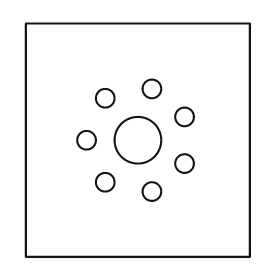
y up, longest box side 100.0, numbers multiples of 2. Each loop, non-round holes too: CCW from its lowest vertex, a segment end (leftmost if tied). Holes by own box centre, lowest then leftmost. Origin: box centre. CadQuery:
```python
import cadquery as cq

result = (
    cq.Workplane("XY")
    .moveTo(-48.0, -50.0)
    .lineTo(48.0, -50.0)
    .lineTo(48.0, 50.0)
    .lineTo(-48.0, 50.0)
    .close()
    .moveTo(6.0, -22.0)
    .circle(4.0)
    .moveTo(-14.0, -18.0)
    .circle(4.0)
    .moveTo(20.0, -10.0)
    .circle(4.0)
    .moveTo(-22.0, 0.0)
    .circle(4.0)
    .moveTo(0.0, 0.0)
    .circle(10.0)
    .moveTo(20.0, 10.0)
    .circle(4.0)
    .moveTo(-14.0, 18.0)
    .circle(4.0)
    .moveTo(6.0, 22.0)
    .circle(4.0)
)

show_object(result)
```